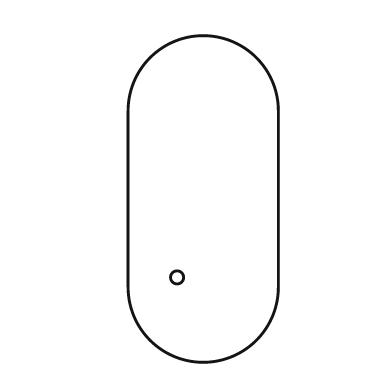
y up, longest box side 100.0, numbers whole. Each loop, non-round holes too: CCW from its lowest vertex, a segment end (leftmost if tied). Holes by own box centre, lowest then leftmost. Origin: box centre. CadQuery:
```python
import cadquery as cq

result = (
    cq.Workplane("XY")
    .moveTo(-23.0, -27.0)
    .threePointArc((0.0, -50.0), (23.0, -27.0))
    .lineTo(23.0, 27.0)
    .threePointArc((0.0, 50.0), (-23.0, 27.0))
    .close()
    .moveTo(-8.0, -24.0)
    .circle(2.0)
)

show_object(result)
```